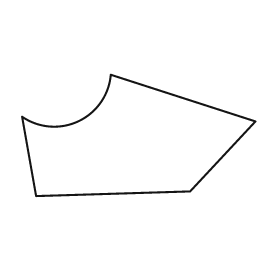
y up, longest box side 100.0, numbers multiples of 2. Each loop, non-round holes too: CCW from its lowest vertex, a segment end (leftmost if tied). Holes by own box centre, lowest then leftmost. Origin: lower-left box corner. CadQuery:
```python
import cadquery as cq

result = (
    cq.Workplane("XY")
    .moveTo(6.0, 0.0)
    .lineTo(72.0, 2.0)
    .lineTo(100.0, 32.0)
    .lineTo(38.0, 52.0)
    .threePointArc((24.0, 32.0), (0.0, 34.0))
    .close()
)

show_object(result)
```